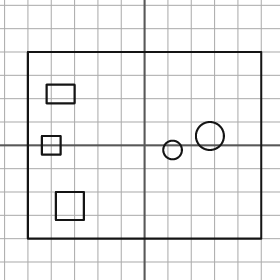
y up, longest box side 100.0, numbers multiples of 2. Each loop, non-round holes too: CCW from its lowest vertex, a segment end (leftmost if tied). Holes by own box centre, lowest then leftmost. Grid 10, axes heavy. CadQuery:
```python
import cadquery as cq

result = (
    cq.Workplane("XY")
    .moveTo(-50.0, -40.0)
    .lineTo(50.0, -40.0)
    .lineTo(50.0, 40.0)
    .lineTo(-50.0, 40.0)
    .close()
    .moveTo(-38.0, -32.0)
    .lineTo(-26.0, -32.0)
    .lineTo(-26.0, -20.0)
    .lineTo(-38.0, -20.0)
    .close()
    .moveTo(12.0, -2.0)
    .circle(4.0)
    .moveTo(-44.0, -4.0)
    .lineTo(-36.0, -4.0)
    .lineTo(-36.0, 4.0)
    .lineTo(-44.0, 4.0)
    .close()
    .moveTo(28.0, 4.0)
    .circle(6.0)
    .moveTo(-42.0, 18.0)
    .lineTo(-30.0, 18.0)
    .lineTo(-30.0, 26.0)
    .lineTo(-42.0, 26.0)
    .close()
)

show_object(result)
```